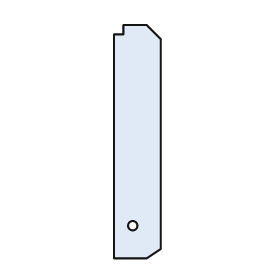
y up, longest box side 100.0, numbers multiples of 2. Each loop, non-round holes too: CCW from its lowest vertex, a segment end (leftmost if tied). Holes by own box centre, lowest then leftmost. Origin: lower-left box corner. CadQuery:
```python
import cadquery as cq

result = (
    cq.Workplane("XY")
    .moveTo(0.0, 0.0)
    .lineTo(14.0, 0.0)
    .lineTo(20.0, 4.0)
    .lineTo(20.0, 94.0)
    .lineTo(14.0, 100.0)
    .lineTo(4.0, 100.0)
    .lineTo(4.0, 96.0)
    .lineTo(0.0, 96.0)
    .close()
    .moveTo(8.0, 14.0)
    .circle(2.0)
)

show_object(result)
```